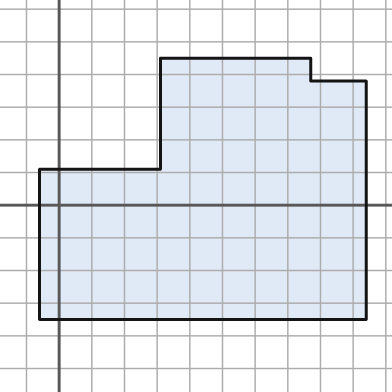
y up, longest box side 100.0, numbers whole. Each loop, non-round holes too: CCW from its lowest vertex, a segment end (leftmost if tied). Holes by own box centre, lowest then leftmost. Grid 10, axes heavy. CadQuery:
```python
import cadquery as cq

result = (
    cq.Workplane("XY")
    .moveTo(-6.0, -35.0)
    .lineTo(94.0, -35.0)
    .lineTo(94.0, 38.0)
    .lineTo(77.0, 38.0)
    .lineTo(77.0, 45.0)
    .lineTo(31.0, 45.0)
    .lineTo(31.0, 11.0)
    .lineTo(-6.0, 11.0)
    .close()
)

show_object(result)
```